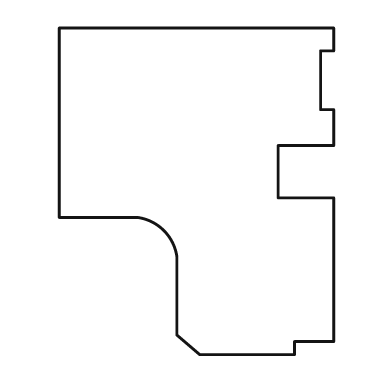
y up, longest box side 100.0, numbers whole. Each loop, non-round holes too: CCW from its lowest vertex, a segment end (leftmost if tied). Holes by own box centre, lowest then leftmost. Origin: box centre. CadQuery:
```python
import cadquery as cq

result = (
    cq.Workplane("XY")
    .moveTo(1.0, -50.0)
    .lineTo(30.0, -50.0)
    .lineTo(30.0, -46.0)
    .lineTo(42.0, -46.0)
    .lineTo(42.0, -2.0)
    .lineTo(25.0, -2.0)
    .lineTo(25.0, 14.0)
    .lineTo(42.0, 14.0)
    .lineTo(42.0, 25.0)
    .lineTo(38.0, 25.0)
    .lineTo(38.0, 43.0)
    .lineTo(42.0, 43.0)
    .lineTo(42.0, 50.0)
    .lineTo(-42.0, 50.0)
    .lineTo(-42.0, -8.0)
    .lineTo(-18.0, -8.0)
    .threePointArc((-10.0, -12.0), (-6.0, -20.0))
    .lineTo(-6.0, -44.0)
    .close()
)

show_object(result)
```